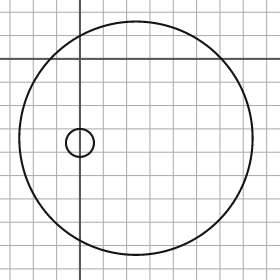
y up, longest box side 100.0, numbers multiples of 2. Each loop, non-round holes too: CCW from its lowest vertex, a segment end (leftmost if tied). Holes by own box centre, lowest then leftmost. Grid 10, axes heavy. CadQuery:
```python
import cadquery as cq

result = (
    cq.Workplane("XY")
    .moveTo(24.0, -34.0)
    .circle(50.0)
    .moveTo(0.0, -36.0)
    .circle(6.0)
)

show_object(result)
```